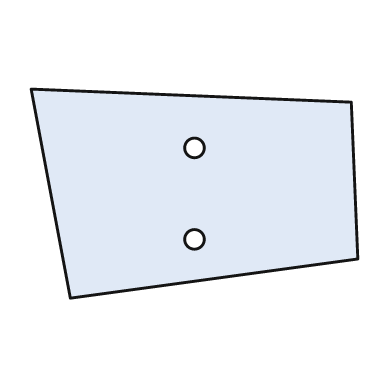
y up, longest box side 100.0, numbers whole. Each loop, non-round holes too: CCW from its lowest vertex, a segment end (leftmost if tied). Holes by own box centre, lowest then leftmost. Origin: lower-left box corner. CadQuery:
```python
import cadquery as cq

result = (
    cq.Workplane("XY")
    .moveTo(12.0, 0.0)
    .lineTo(100.0, 12.0)
    .lineTo(98.0, 60.0)
    .lineTo(0.0, 64.0)
    .close()
    .moveTo(50.0, 18.0)
    .circle(3.0)
    .moveTo(50.0, 46.0)
    .circle(3.0)
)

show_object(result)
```